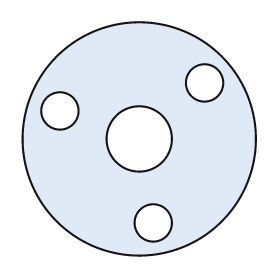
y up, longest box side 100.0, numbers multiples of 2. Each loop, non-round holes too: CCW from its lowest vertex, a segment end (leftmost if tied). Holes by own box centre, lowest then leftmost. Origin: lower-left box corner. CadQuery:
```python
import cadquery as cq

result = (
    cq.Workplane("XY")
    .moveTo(50.0, 50.0)
    .circle(50.0)
    .moveTo(56.0, 14.0)
    .circle(8.0)
    .moveTo(50.0, 50.0)
    .circle(14.0)
    .moveTo(16.0, 62.0)
    .circle(8.0)
    .moveTo(78.0, 74.0)
    .circle(8.0)
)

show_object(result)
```